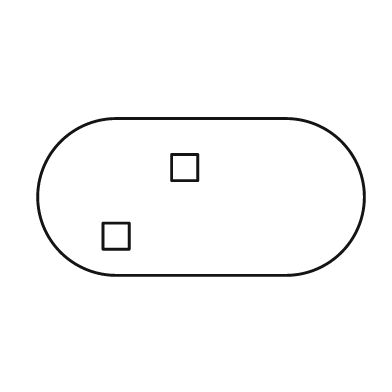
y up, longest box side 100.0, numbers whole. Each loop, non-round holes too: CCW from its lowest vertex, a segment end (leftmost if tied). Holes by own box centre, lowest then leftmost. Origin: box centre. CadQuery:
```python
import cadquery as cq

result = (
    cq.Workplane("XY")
    .moveTo(-26.0, -24.0)
    .lineTo(26.0, -24.0)
    .threePointArc((50.0, 0.0), (26.0, 24.0))
    .lineTo(-26.0, 24.0)
    .threePointArc((-50.0, 0.0), (-26.0, -24.0))
    .close()
    .moveTo(-30.0, -16.0)
    .lineTo(-22.0, -16.0)
    .lineTo(-22.0, -8.0)
    .lineTo(-30.0, -8.0)
    .close()
    .moveTo(-9.0, 5.0)
    .lineTo(-1.0, 5.0)
    .lineTo(-1.0, 13.0)
    .lineTo(-9.0, 13.0)
    .close()
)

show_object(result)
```